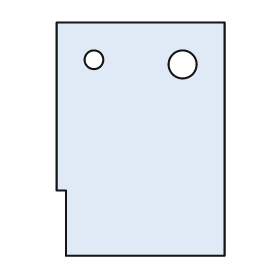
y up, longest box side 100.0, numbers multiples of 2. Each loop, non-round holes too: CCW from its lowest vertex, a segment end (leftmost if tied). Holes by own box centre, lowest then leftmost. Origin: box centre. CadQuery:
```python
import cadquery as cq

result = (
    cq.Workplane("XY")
    .moveTo(-32.0, -50.0)
    .lineTo(36.0, -50.0)
    .lineTo(36.0, 50.0)
    .lineTo(-36.0, 50.0)
    .lineTo(-36.0, -22.0)
    .lineTo(-32.0, -22.0)
    .close()
    .moveTo(18.0, 32.0)
    .circle(6.0)
    .moveTo(-20.0, 34.0)
    .circle(4.0)
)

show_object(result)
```